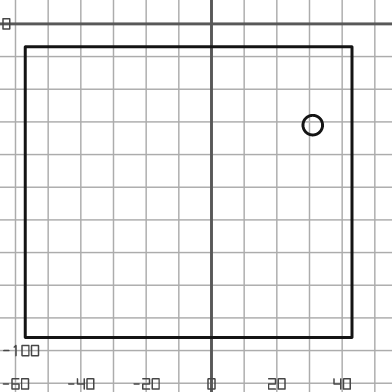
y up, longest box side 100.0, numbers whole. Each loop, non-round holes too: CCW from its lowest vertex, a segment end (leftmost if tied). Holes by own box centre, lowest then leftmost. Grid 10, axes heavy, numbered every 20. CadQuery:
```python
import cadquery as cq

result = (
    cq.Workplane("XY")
    .moveTo(-57.0, -96.0)
    .lineTo(43.0, -96.0)
    .lineTo(43.0, -7.0)
    .lineTo(-57.0, -7.0)
    .close()
    .moveTo(31.0, -31.0)
    .circle(3.0)
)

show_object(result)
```